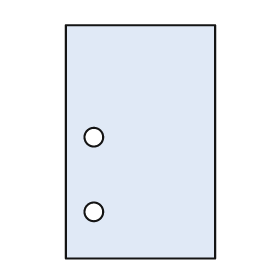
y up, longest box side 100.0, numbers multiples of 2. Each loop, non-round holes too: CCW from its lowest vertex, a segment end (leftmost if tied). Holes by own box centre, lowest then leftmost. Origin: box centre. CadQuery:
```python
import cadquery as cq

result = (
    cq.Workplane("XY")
    .moveTo(-32.0, -50.0)
    .lineTo(32.0, -50.0)
    .lineTo(32.0, 50.0)
    .lineTo(-32.0, 50.0)
    .close()
    .moveTo(-20.0, -30.0)
    .circle(4.0)
    .moveTo(-20.0, 2.0)
    .circle(4.0)
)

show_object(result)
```